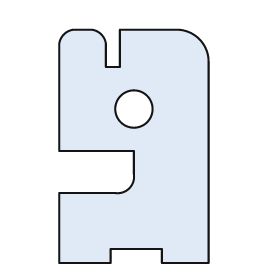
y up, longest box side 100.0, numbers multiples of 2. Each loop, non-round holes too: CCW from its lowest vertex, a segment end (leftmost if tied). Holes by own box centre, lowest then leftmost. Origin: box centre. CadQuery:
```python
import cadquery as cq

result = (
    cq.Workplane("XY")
    .moveTo(-32.0, -50.0)
    .lineTo(-10.0, -50.0)
    .lineTo(-10.0, -44.0)
    .lineTo(12.0, -44.0)
    .lineTo(12.0, -50.0)
    .lineTo(32.0, -50.0)
    .lineTo(32.0, 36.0)
    .threePointArc((28.0, 46.0), (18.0, 50.0))
    .lineTo(-6.0, 50.0)
    .lineTo(-6.0, 34.0)
    .lineTo(-12.0, 34.0)
    .lineTo(-12.0, 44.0)
    .threePointArc((-14.0, 48.0), (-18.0, 50.0))
    .lineTo(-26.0, 50.0)
    .threePointArc((-30.0, 48.0), (-32.0, 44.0))
    .lineTo(-32.0, -2.0)
    .lineTo(0.0, -2.0)
    .lineTo(0.0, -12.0)
    .threePointArc((-2.0, -18.0), (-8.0, -20.0))
    .lineTo(-32.0, -20.0)
    .close()
    .moveTo(0.0, 16.0)
    .circle(8.0)
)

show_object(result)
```